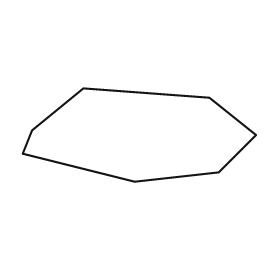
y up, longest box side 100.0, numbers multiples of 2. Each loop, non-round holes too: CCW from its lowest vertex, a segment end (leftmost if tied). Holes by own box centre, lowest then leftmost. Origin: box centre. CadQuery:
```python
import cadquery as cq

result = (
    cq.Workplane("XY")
    .moveTo(-2.0, -20.0)
    .lineTo(34.0, -16.0)
    .lineTo(50.0, 0.0)
    .lineTo(30.0, 16.0)
    .lineTo(-24.0, 20.0)
    .lineTo(-46.0, 2.0)
    .lineTo(-50.0, -8.0)
    .close()
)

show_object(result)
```